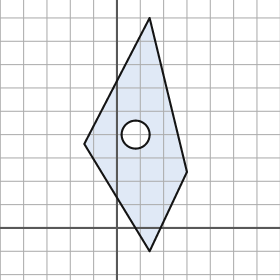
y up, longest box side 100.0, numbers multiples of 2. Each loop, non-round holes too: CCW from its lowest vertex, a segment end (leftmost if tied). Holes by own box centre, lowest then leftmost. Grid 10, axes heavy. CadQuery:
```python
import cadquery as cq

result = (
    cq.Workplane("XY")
    .moveTo(14.0, -10.0)
    .lineTo(30.0, 24.0)
    .lineTo(14.0, 90.0)
    .lineTo(-14.0, 36.0)
    .close()
    .moveTo(8.0, 40.0)
    .circle(6.0)
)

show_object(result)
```